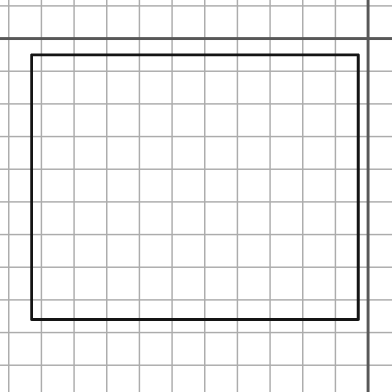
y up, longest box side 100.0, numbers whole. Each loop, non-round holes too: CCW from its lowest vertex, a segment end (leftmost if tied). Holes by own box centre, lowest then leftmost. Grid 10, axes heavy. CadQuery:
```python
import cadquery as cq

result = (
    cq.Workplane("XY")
    .moveTo(-103.0, -86.0)
    .lineTo(-3.0, -86.0)
    .lineTo(-3.0, -5.0)
    .lineTo(-103.0, -5.0)
    .close()
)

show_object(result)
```